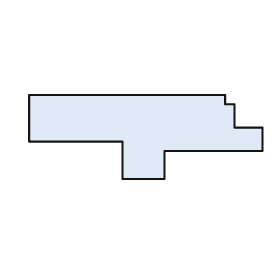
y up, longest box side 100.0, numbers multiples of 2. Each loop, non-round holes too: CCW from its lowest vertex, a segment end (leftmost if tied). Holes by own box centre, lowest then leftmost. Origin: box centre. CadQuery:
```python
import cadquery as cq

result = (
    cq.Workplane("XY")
    .moveTo(-10.0, -18.0)
    .lineTo(8.0, -18.0)
    .lineTo(8.0, -6.0)
    .lineTo(50.0, -6.0)
    .lineTo(50.0, 4.0)
    .lineTo(38.0, 4.0)
    .lineTo(38.0, 14.0)
    .lineTo(34.0, 14.0)
    .lineTo(34.0, 18.0)
    .lineTo(-50.0, 18.0)
    .lineTo(-50.0, -2.0)
    .lineTo(-10.0, -2.0)
    .close()
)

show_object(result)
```